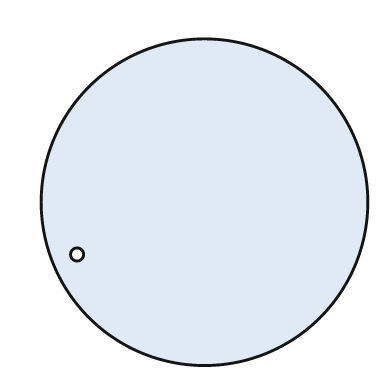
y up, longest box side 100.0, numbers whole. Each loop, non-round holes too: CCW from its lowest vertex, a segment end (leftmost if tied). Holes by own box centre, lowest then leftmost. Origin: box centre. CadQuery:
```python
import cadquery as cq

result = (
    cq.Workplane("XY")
    .moveTo(0.0, 0.0)
    .circle(50.0)
    .moveTo(-39.0, -16.0)
    .circle(2.0)
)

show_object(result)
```